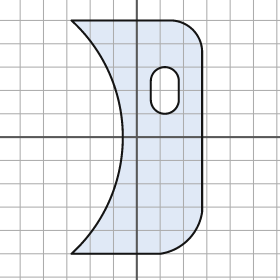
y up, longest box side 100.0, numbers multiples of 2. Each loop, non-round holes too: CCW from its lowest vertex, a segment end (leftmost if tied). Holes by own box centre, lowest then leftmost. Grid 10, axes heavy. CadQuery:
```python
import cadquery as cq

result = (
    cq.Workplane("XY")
    .moveTo(-28.0, -50.0)
    .lineTo(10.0, -50.0)
    .threePointArc((22.0, -44.0), (28.0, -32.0))
    .lineTo(28.0, 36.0)
    .threePointArc((24.0, 46.0), (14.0, 50.0))
    .lineTo(-28.0, 50.0)
    .threePointArc((-6.0, 0.0), (-28.0, -50.0))
    .close()
    .moveTo(6.0, 16.0)
    .threePointArc((12.0, 10.0), (18.0, 16.0))
    .lineTo(18.0, 24.0)
    .threePointArc((12.0, 30.0), (6.0, 24.0))
    .close()
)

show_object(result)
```